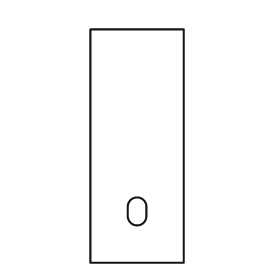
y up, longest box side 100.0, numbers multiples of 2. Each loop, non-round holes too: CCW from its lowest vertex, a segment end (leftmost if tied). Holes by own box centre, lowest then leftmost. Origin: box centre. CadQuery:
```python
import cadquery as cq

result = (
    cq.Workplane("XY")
    .moveTo(-20.0, -50.0)
    .lineTo(20.0, -50.0)
    .lineTo(20.0, 50.0)
    .lineTo(-20.0, 50.0)
    .close()
    .moveTo(-4.0, -30.0)
    .threePointArc((0.0, -34.0), (4.0, -30.0))
    .lineTo(4.0, -26.0)
    .threePointArc((0.0, -22.0), (-4.0, -26.0))
    .close()
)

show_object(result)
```